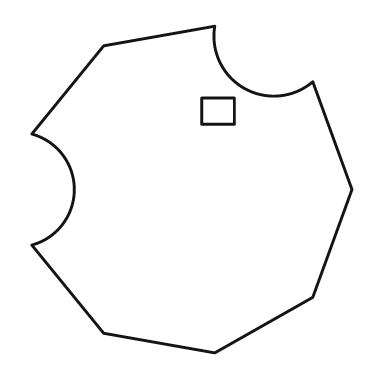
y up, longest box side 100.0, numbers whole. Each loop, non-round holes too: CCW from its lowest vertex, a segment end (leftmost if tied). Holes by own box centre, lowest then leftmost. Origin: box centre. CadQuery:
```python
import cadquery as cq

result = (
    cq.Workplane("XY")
    .moveTo(7.0, -50.0)
    .lineTo(37.0, -33.0)
    .lineTo(49.0, 0.0)
    .lineTo(37.0, 33.0)
    .threePointArc((16.0, 31.0), (7.0, 50.0))
    .lineTo(-27.0, 44.0)
    .lineTo(-49.0, 17.0)
    .threePointArc((-36.0, 0.0), (-49.0, -17.0))
    .lineTo(-27.0, -44.0)
    .close()
    .moveTo(3.0, 20.0)
    .lineTo(13.0, 20.0)
    .lineTo(13.0, 28.0)
    .lineTo(3.0, 28.0)
    .close()
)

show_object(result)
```